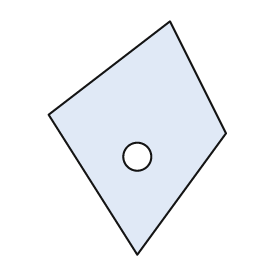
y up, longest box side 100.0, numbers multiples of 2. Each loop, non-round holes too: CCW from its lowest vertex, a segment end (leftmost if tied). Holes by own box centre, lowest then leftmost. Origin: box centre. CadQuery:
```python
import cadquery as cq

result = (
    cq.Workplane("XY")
    .moveTo(0.0, -50.0)
    .lineTo(38.0, 2.0)
    .lineTo(14.0, 50.0)
    .lineTo(-38.0, 10.0)
    .close()
    .moveTo(0.0, -8.0)
    .circle(6.0)
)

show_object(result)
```